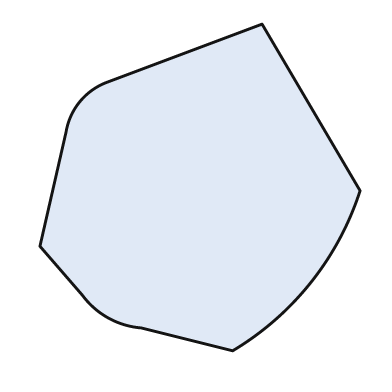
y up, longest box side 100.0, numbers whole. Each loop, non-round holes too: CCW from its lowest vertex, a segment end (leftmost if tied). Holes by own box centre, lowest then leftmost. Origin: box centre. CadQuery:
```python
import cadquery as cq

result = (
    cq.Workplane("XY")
    .moveTo(10.0, -50.0)
    .threePointArc((34.0, -29.0), (49.0, -1.0))
    .lineTo(19.0, 50.0)
    .lineTo(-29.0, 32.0)
    .threePointArc((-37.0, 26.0), (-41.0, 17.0))
    .lineTo(-49.0, -18.0)
    .lineTo(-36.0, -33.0)
    .threePointArc((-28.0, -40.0), (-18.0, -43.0))
    .close()
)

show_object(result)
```